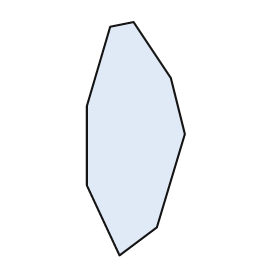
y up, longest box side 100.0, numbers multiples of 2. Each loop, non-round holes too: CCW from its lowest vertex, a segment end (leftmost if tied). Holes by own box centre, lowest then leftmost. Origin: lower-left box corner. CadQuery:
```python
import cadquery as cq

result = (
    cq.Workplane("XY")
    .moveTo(14.0, 0.0)
    .lineTo(30.0, 12.0)
    .lineTo(42.0, 52.0)
    .lineTo(36.0, 76.0)
    .lineTo(20.0, 100.0)
    .lineTo(10.0, 98.0)
    .lineTo(0.0, 64.0)
    .lineTo(0.0, 30.0)
    .close()
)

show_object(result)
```